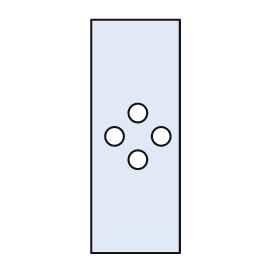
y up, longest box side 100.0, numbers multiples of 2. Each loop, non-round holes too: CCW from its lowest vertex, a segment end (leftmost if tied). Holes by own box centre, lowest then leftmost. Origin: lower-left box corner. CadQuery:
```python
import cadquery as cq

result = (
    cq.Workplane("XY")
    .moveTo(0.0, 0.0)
    .lineTo(38.0, 0.0)
    .lineTo(38.0, 100.0)
    .lineTo(0.0, 100.0)
    .close()
    .moveTo(20.0, 40.0)
    .circle(4.0)
    .moveTo(10.0, 50.0)
    .circle(4.0)
    .moveTo(30.0, 50.0)
    .circle(4.0)
    .moveTo(20.0, 60.0)
    .circle(4.0)
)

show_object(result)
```